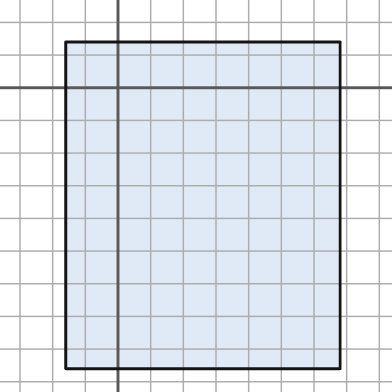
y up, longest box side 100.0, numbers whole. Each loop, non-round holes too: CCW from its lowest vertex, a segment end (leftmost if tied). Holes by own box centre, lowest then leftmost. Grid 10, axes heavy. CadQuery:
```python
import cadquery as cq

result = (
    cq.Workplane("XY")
    .moveTo(-16.0, -86.0)
    .lineTo(68.0, -86.0)
    .lineTo(68.0, 14.0)
    .lineTo(-16.0, 14.0)
    .close()
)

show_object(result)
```